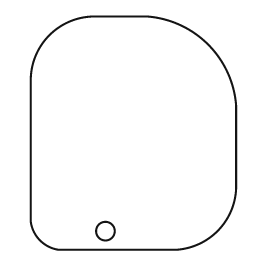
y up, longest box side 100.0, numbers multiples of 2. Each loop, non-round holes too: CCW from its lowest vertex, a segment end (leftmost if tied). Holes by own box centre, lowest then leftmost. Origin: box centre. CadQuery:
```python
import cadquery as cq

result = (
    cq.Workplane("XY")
    .moveTo(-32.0, -50.0)
    .lineTo(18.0, -50.0)
    .threePointArc((36.0, -42.0), (44.0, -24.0))
    .lineTo(44.0, 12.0)
    .threePointArc((32.0, 38.0), (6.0, 50.0))
    .lineTo(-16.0, 50.0)
    .threePointArc((-36.0, 42.0), (-44.0, 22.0))
    .lineTo(-44.0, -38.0)
    .threePointArc((-40.0, -46.0), (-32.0, -50.0))
    .close()
    .moveTo(-12.0, -42.0)
    .circle(4.0)
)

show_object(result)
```